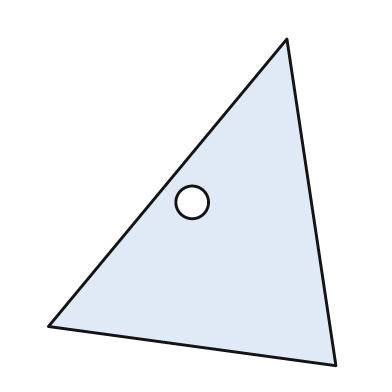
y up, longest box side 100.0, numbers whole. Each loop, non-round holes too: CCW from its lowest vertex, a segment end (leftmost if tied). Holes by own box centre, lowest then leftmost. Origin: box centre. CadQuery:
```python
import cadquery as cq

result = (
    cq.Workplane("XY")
    .moveTo(44.0, -50.0)
    .lineTo(29.0, 50.0)
    .lineTo(-44.0, -38.0)
    .close()
    .moveTo(0.0, 0.0)
    .circle(5.0)
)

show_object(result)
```